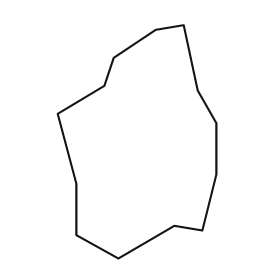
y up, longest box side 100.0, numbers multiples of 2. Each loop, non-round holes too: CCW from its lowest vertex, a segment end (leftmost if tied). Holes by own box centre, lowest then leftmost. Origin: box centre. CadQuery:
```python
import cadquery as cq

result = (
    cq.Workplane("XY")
    .moveTo(-8.0, -50.0)
    .lineTo(16.0, -36.0)
    .lineTo(28.0, -38.0)
    .lineTo(34.0, -14.0)
    .lineTo(34.0, 8.0)
    .lineTo(26.0, 22.0)
    .lineTo(20.0, 50.0)
    .lineTo(8.0, 48.0)
    .lineTo(-10.0, 36.0)
    .lineTo(-14.0, 24.0)
    .lineTo(-34.0, 12.0)
    .lineTo(-26.0, -18.0)
    .lineTo(-26.0, -40.0)
    .close()
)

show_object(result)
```